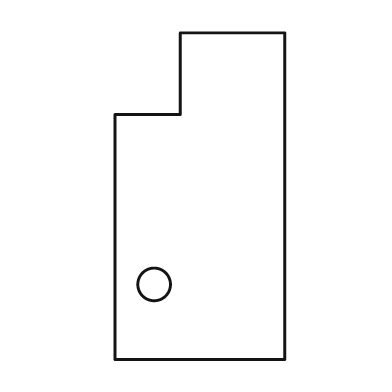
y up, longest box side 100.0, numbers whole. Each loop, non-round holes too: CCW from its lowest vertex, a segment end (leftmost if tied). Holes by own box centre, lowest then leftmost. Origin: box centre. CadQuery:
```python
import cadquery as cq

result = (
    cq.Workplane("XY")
    .moveTo(-26.0, -50.0)
    .lineTo(26.0, -50.0)
    .lineTo(26.0, 50.0)
    .lineTo(-6.0, 50.0)
    .lineTo(-6.0, 25.0)
    .lineTo(-26.0, 25.0)
    .close()
    .moveTo(-14.0, -27.0)
    .circle(5.0)
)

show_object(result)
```